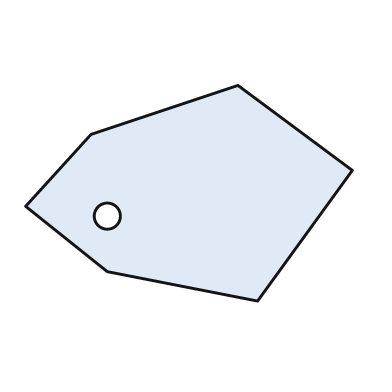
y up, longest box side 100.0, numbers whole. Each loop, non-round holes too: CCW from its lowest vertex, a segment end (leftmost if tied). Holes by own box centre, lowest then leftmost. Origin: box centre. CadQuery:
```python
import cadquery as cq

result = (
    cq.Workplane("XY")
    .moveTo(21.0, -33.0)
    .lineTo(50.0, 7.0)
    .lineTo(15.0, 33.0)
    .lineTo(-30.0, 18.0)
    .lineTo(-50.0, -4.0)
    .lineTo(-25.0, -24.0)
    .close()
    .moveTo(-25.0, -7.0)
    .circle(4.0)
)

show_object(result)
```